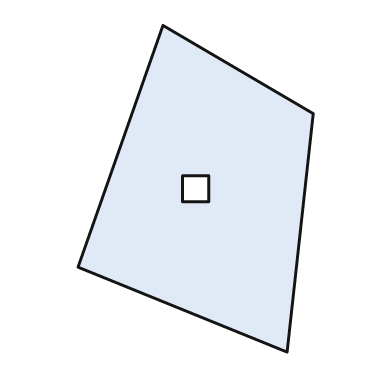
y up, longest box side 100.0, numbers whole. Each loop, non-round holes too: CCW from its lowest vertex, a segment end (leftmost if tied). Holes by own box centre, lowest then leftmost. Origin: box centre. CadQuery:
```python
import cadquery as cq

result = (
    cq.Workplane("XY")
    .moveTo(28.0, -50.0)
    .lineTo(36.0, 23.0)
    .lineTo(-10.0, 50.0)
    .lineTo(-36.0, -24.0)
    .close()
    .moveTo(-4.0, -4.0)
    .lineTo(4.0, -4.0)
    .lineTo(4.0, 4.0)
    .lineTo(-4.0, 4.0)
    .close()
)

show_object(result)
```